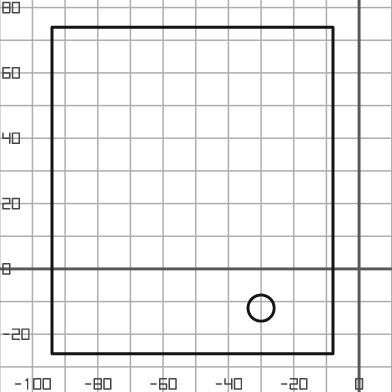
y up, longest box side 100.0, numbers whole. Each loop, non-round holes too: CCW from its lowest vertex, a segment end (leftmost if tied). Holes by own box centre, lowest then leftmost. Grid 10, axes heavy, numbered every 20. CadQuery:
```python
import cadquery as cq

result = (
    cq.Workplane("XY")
    .moveTo(-94.0, -26.0)
    .lineTo(-8.0, -26.0)
    .lineTo(-8.0, 74.0)
    .lineTo(-94.0, 74.0)
    .close()
    .moveTo(-30.0, -12.0)
    .circle(4.0)
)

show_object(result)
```